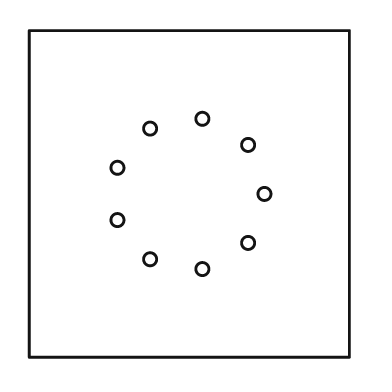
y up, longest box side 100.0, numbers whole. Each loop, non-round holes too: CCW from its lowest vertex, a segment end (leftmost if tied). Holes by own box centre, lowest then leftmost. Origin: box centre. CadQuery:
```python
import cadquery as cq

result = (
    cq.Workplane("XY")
    .moveTo(-49.0, -50.0)
    .lineTo(49.0, -50.0)
    .lineTo(49.0, 50.0)
    .lineTo(-49.0, 50.0)
    .close()
    .moveTo(4.0, -23.0)
    .circle(2.0)
    .moveTo(-12.0, -20.0)
    .circle(2.0)
    .moveTo(18.0, -15.0)
    .circle(2.0)
    .moveTo(-22.0, -8.0)
    .circle(2.0)
    .moveTo(23.0, 0.0)
    .circle(2.0)
    .moveTo(-22.0, 8.0)
    .circle(2.0)
    .moveTo(18.0, 15.0)
    .circle(2.0)
    .moveTo(-12.0, 20.0)
    .circle(2.0)
    .moveTo(4.0, 23.0)
    .circle(2.0)
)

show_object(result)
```